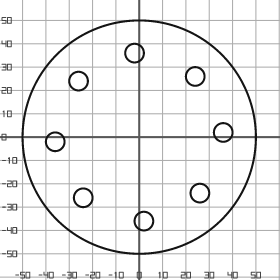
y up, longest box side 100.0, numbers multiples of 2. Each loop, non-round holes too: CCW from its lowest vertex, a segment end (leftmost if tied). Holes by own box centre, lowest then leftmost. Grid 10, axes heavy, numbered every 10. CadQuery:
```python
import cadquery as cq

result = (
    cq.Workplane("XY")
    .moveTo(0.0, 0.0)
    .circle(50.0)
    .moveTo(2.0, -36.0)
    .circle(4.0)
    .moveTo(-24.0, -26.0)
    .circle(4.0)
    .moveTo(26.0, -24.0)
    .circle(4.0)
    .moveTo(-36.0, -2.0)
    .circle(4.0)
    .moveTo(36.0, 2.0)
    .circle(4.0)
    .moveTo(-26.0, 24.0)
    .circle(4.0)
    .moveTo(24.0, 26.0)
    .circle(4.0)
    .moveTo(-2.0, 36.0)
    .circle(4.0)
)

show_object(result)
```